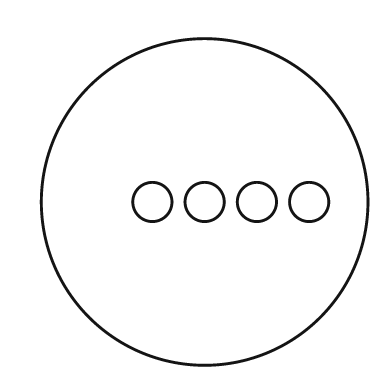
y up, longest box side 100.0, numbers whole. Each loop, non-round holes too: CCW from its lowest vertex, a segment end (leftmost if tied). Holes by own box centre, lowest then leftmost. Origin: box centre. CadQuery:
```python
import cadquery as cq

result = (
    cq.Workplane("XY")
    .moveTo(0.0, 0.0)
    .circle(50.0)
    .moveTo(-16.0, 0.0)
    .circle(6.0)
    .moveTo(0.0, 0.0)
    .circle(6.0)
    .moveTo(16.0, 0.0)
    .circle(6.0)
    .moveTo(32.0, 0.0)
    .circle(6.0)
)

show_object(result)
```